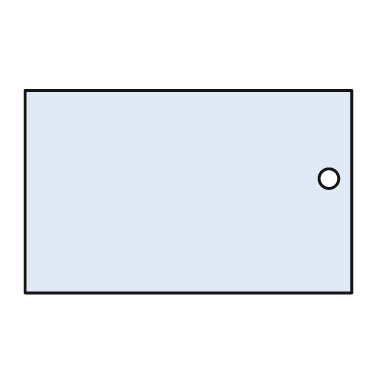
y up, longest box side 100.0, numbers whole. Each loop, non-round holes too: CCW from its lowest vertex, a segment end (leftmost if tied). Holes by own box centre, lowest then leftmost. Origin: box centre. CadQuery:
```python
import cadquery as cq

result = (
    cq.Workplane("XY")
    .moveTo(-50.0, -31.0)
    .lineTo(50.0, -31.0)
    .lineTo(50.0, 31.0)
    .lineTo(-50.0, 31.0)
    .close()
    .moveTo(43.0, 4.0)
    .circle(3.0)
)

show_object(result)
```